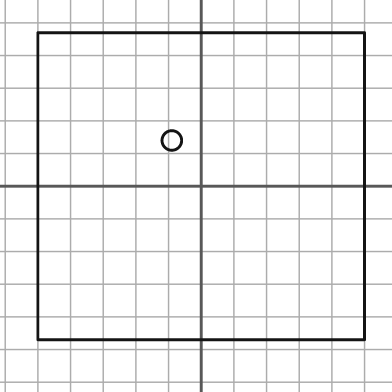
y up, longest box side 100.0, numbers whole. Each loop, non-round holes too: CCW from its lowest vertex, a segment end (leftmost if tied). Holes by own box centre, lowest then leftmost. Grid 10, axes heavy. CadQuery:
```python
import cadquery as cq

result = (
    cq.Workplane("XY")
    .moveTo(-50.0, -47.0)
    .lineTo(50.0, -47.0)
    .lineTo(50.0, 47.0)
    .lineTo(-50.0, 47.0)
    .close()
    .moveTo(-9.0, 14.0)
    .circle(3.0)
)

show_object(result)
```